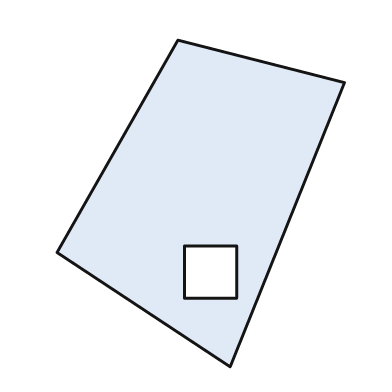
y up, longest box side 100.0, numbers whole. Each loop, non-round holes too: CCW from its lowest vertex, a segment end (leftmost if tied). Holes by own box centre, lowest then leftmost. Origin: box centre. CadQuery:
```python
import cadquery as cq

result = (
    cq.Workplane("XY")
    .moveTo(9.0, -50.0)
    .lineTo(44.0, 37.0)
    .lineTo(-7.0, 50.0)
    .lineTo(-44.0, -15.0)
    .close()
    .moveTo(-5.0, -29.0)
    .lineTo(11.0, -29.0)
    .lineTo(11.0, -13.0)
    .lineTo(-5.0, -13.0)
    .close()
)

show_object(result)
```